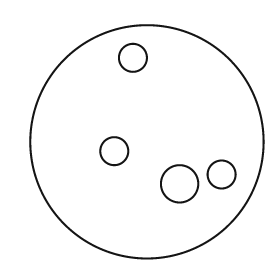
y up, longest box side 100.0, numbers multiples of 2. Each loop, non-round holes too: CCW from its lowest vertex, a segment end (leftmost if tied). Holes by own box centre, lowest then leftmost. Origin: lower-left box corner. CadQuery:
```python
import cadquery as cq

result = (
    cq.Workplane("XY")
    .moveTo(50.0, 50.0)
    .circle(50.0)
    .moveTo(64.0, 32.0)
    .circle(8.0)
    .moveTo(82.0, 36.0)
    .circle(6.0)
    .moveTo(36.0, 46.0)
    .circle(6.0)
    .moveTo(44.0, 86.0)
    .circle(6.0)
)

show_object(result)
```